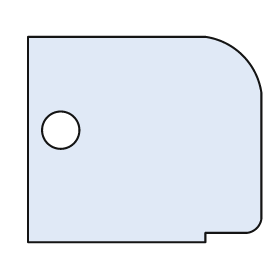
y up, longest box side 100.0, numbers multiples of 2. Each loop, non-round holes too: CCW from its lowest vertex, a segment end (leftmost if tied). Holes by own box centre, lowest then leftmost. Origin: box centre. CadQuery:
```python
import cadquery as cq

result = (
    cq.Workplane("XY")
    .moveTo(-50.0, -44.0)
    .lineTo(26.0, -44.0)
    .lineTo(26.0, -40.0)
    .lineTo(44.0, -40.0)
    .threePointArc((48.0, -38.0), (50.0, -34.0))
    .lineTo(50.0, 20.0)
    .threePointArc((42.0, 36.0), (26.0, 44.0))
    .lineTo(-50.0, 44.0)
    .close()
    .moveTo(-36.0, 4.0)
    .circle(8.0)
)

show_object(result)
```